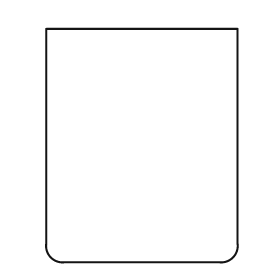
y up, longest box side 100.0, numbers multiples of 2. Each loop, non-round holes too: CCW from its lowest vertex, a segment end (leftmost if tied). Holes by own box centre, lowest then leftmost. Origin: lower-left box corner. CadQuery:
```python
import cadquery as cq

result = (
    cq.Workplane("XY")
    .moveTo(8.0, 0.0)
    .lineTo(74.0, 0.0)
    .threePointArc((80.0, 2.0), (82.0, 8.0))
    .lineTo(82.0, 100.0)
    .lineTo(0.0, 100.0)
    .lineTo(0.0, 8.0)
    .threePointArc((2.0, 2.0), (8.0, 0.0))
    .close()
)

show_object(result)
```